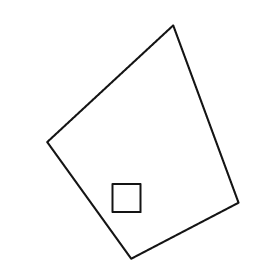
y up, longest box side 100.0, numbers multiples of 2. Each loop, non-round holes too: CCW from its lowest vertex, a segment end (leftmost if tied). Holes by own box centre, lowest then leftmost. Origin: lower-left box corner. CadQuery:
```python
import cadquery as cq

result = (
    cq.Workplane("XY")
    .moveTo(36.0, 0.0)
    .lineTo(82.0, 24.0)
    .lineTo(54.0, 100.0)
    .lineTo(0.0, 50.0)
    .close()
    .moveTo(28.0, 20.0)
    .lineTo(40.0, 20.0)
    .lineTo(40.0, 32.0)
    .lineTo(28.0, 32.0)
    .close()
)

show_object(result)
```